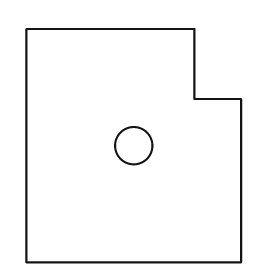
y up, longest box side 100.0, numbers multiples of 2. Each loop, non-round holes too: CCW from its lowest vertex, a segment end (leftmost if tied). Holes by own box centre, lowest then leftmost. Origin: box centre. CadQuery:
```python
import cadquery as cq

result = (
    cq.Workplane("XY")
    .moveTo(-46.0, -50.0)
    .lineTo(46.0, -50.0)
    .lineTo(46.0, 20.0)
    .lineTo(26.0, 20.0)
    .lineTo(26.0, 50.0)
    .lineTo(-46.0, 50.0)
    .close()
    .moveTo(0.0, 0.0)
    .circle(8.0)
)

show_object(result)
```